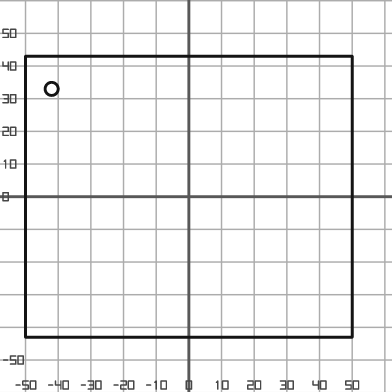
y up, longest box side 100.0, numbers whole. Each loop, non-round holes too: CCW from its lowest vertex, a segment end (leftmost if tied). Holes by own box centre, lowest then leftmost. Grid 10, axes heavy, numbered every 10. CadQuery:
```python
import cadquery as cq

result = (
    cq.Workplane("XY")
    .moveTo(-50.0, -43.0)
    .lineTo(50.0, -43.0)
    .lineTo(50.0, 43.0)
    .lineTo(-50.0, 43.0)
    .close()
    .moveTo(-42.0, 33.0)
    .circle(2.0)
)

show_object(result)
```